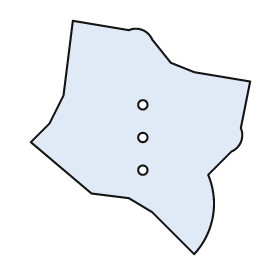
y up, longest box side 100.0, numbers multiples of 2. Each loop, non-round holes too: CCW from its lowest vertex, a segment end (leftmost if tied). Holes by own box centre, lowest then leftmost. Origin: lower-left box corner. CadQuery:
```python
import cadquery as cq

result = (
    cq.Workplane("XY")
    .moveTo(70.0, 0.0)
    .threePointArc((78.0, 16.0), (76.0, 34.0))
    .lineTo(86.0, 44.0)
    .threePointArc((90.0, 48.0), (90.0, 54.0))
    .lineTo(94.0, 74.0)
    .lineTo(70.0, 78.0)
    .lineTo(60.0, 82.0)
    .lineTo(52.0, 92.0)
    .threePointArc((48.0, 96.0), (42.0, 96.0))
    .lineTo(18.0, 100.0)
    .lineTo(14.0, 68.0)
    .lineTo(8.0, 56.0)
    .lineTo(0.0, 48.0)
    .lineTo(26.0, 26.0)
    .lineTo(42.0, 24.0)
    .lineTo(52.0, 18.0)
    .close()
    .moveTo(48.0, 36.0)
    .circle(2.0)
    .moveTo(48.0, 50.0)
    .circle(2.0)
    .moveTo(48.0, 64.0)
    .circle(2.0)
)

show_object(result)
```